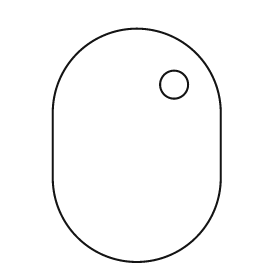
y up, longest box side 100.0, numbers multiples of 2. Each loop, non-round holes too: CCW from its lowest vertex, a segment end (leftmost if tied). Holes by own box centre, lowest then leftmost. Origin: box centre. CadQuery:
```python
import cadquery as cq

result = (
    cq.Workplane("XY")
    .moveTo(-36.0, -14.0)
    .threePointArc((0.0, -50.0), (36.0, -14.0))
    .lineTo(36.0, 14.0)
    .threePointArc((0.0, 50.0), (-36.0, 14.0))
    .close()
    .moveTo(16.0, 26.0)
    .circle(6.0)
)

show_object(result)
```